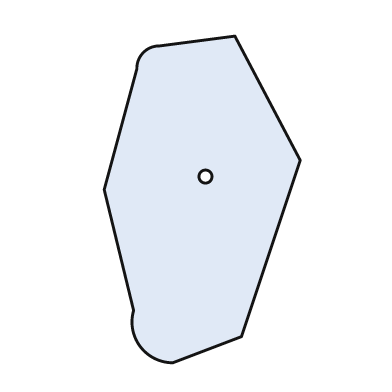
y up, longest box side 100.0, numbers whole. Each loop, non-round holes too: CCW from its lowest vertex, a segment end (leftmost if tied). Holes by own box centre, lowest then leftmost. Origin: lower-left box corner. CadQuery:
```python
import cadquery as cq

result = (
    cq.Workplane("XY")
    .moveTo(21.0, 0.0)
    .lineTo(42.0, 8.0)
    .lineTo(60.0, 62.0)
    .lineTo(40.0, 100.0)
    .lineTo(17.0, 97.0)
    .threePointArc((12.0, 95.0), (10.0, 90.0))
    .lineTo(0.0, 53.0)
    .lineTo(9.0, 16.0)
    .threePointArc((11.0, 5.0), (21.0, 0.0))
    .close()
    .moveTo(31.0, 57.0)
    .circle(2.0)
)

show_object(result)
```